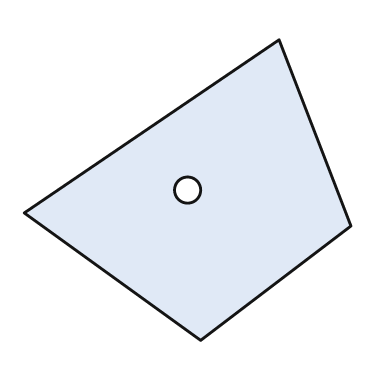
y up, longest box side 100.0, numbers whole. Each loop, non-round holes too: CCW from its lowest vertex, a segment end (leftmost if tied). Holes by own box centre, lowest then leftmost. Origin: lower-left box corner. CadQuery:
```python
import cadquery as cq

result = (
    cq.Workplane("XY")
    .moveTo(54.0, 0.0)
    .lineTo(100.0, 35.0)
    .lineTo(78.0, 92.0)
    .lineTo(0.0, 39.0)
    .close()
    .moveTo(50.0, 46.0)
    .circle(4.0)
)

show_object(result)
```